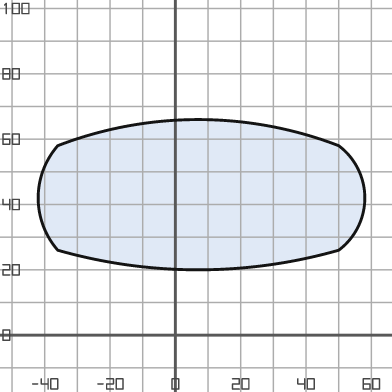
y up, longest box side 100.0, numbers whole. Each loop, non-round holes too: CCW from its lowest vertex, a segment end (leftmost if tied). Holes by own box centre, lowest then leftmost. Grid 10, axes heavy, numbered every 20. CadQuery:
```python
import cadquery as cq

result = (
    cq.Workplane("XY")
    .moveTo(-36.0, 26.0)
    .threePointArc((7.0, 20.0), (50.0, 26.0))
    .threePointArc((58.0, 42.0), (50.0, 58.0))
    .threePointArc((7.0, 66.0), (-36.0, 58.0))
    .threePointArc((-42.0, 42.0), (-36.0, 26.0))
    .close()
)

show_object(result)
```